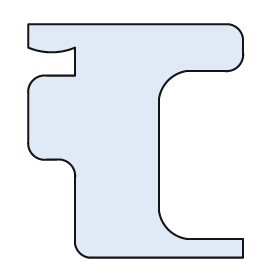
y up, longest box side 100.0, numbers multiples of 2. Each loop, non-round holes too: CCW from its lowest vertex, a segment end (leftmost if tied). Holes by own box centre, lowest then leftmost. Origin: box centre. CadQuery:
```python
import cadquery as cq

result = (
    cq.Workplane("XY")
    .moveTo(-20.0, -50.0)
    .lineTo(46.0, -50.0)
    .lineTo(46.0, -42.0)
    .lineTo(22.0, -42.0)
    .threePointArc((14.0, -38.0), (10.0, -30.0))
    .lineTo(10.0, 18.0)
    .threePointArc((14.0, 26.0), (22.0, 30.0))
    .lineTo(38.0, 30.0)
    .threePointArc((44.0, 32.0), (46.0, 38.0))
    .lineTo(46.0, 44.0)
    .threePointArc((44.0, 48.0), (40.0, 50.0))
    .lineTo(-46.0, 50.0)
    .lineTo(-46.0, 40.0)
    .threePointArc((-36.0, 38.0), (-26.0, 40.0))
    .lineTo(-26.0, 28.0)
    .lineTo(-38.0, 28.0)
    .threePointArc((-44.0, 26.0), (-46.0, 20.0))
    .lineTo(-46.0, 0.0)
    .threePointArc((-44.0, -6.0), (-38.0, -8.0))
    .lineTo(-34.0, -8.0)
    .threePointArc((-28.0, -10.0), (-26.0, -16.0))
    .lineTo(-26.0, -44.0)
    .threePointArc((-24.0, -48.0), (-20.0, -50.0))
    .close()
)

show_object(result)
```